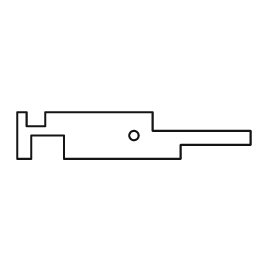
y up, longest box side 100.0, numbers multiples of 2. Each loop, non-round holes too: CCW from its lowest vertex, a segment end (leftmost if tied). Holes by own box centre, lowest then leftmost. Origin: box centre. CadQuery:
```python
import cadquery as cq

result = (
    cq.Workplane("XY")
    .moveTo(-50.0, -10.0)
    .lineTo(-44.0, -10.0)
    .lineTo(-44.0, 0.0)
    .lineTo(-30.0, 0.0)
    .lineTo(-30.0, -10.0)
    .lineTo(20.0, -10.0)
    .lineTo(20.0, -4.0)
    .lineTo(50.0, -4.0)
    .lineTo(50.0, 2.0)
    .lineTo(8.0, 2.0)
    .lineTo(8.0, 10.0)
    .lineTo(-38.0, 10.0)
    .lineTo(-38.0, 4.0)
    .lineTo(-46.0, 4.0)
    .lineTo(-46.0, 10.0)
    .lineTo(-50.0, 10.0)
    .close()
    .moveTo(0.0, 0.0)
    .circle(2.0)
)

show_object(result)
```